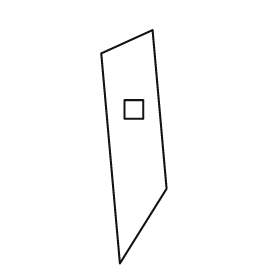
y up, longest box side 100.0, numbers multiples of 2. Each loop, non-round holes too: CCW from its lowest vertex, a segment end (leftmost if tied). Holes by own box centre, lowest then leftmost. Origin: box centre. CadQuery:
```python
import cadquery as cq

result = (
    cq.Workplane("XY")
    .moveTo(-6.0, -50.0)
    .lineTo(14.0, -18.0)
    .lineTo(8.0, 50.0)
    .lineTo(-14.0, 40.0)
    .close()
    .moveTo(-4.0, 12.0)
    .lineTo(4.0, 12.0)
    .lineTo(4.0, 20.0)
    .lineTo(-4.0, 20.0)
    .close()
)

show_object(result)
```